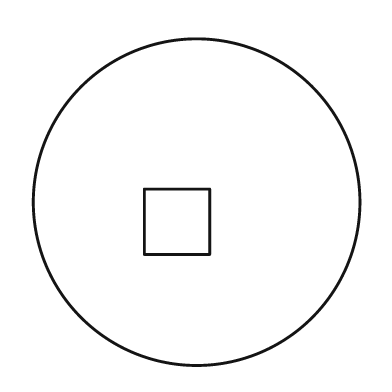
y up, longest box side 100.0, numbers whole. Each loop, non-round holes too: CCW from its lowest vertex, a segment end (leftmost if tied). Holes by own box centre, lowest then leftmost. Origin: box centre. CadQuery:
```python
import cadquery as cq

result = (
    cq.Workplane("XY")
    .moveTo(0.0, 0.0)
    .circle(50.0)
    .moveTo(-16.0, -16.0)
    .lineTo(4.0, -16.0)
    .lineTo(4.0, 4.0)
    .lineTo(-16.0, 4.0)
    .close()
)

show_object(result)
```